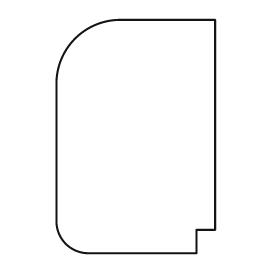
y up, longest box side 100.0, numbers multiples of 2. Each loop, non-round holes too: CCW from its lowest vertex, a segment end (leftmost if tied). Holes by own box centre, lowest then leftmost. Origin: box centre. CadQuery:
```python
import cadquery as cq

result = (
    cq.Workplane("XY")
    .moveTo(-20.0, -50.0)
    .lineTo(26.0, -50.0)
    .lineTo(26.0, -40.0)
    .lineTo(34.0, -40.0)
    .lineTo(34.0, 50.0)
    .lineTo(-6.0, 50.0)
    .threePointArc((-26.0, 42.0), (-34.0, 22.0))
    .lineTo(-34.0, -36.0)
    .threePointArc((-30.0, -46.0), (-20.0, -50.0))
    .close()
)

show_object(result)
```